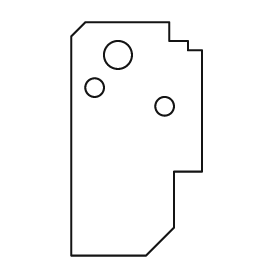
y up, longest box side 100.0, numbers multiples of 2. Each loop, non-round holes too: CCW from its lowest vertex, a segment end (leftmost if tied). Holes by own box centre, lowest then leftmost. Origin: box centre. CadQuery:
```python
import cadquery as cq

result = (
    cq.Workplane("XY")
    .moveTo(-28.0, -50.0)
    .lineTo(4.0, -50.0)
    .lineTo(16.0, -38.0)
    .lineTo(16.0, -14.0)
    .lineTo(28.0, -14.0)
    .lineTo(28.0, 38.0)
    .lineTo(22.0, 38.0)
    .lineTo(22.0, 42.0)
    .lineTo(14.0, 42.0)
    .lineTo(14.0, 50.0)
    .lineTo(-22.0, 50.0)
    .lineTo(-28.0, 44.0)
    .close()
    .moveTo(12.0, 14.0)
    .circle(4.0)
    .moveTo(-18.0, 22.0)
    .circle(4.0)
    .moveTo(-8.0, 36.0)
    .circle(6.0)
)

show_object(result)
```